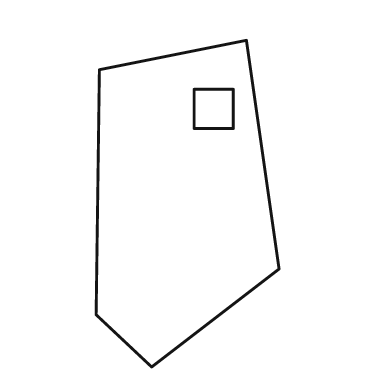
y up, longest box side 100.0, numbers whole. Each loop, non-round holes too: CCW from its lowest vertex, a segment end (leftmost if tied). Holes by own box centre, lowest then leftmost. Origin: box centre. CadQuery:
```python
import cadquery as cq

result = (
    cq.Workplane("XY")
    .moveTo(-11.0, -50.0)
    .lineTo(28.0, -20.0)
    .lineTo(18.0, 50.0)
    .lineTo(-27.0, 41.0)
    .lineTo(-28.0, -34.0)
    .close()
    .moveTo(2.0, 23.0)
    .lineTo(14.0, 23.0)
    .lineTo(14.0, 35.0)
    .lineTo(2.0, 35.0)
    .close()
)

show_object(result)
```